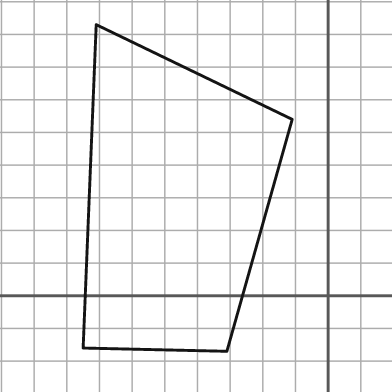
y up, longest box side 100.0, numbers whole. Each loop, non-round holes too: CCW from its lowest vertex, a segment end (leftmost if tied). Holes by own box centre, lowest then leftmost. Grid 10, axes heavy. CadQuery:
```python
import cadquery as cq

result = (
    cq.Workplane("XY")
    .moveTo(-31.0, -17.0)
    .lineTo(-11.0, 54.0)
    .lineTo(-71.0, 83.0)
    .lineTo(-75.0, -16.0)
    .close()
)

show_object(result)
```